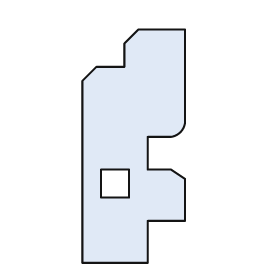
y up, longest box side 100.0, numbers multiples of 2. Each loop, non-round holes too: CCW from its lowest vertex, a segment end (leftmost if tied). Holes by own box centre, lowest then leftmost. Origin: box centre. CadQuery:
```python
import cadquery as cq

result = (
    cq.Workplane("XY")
    .moveTo(-22.0, -50.0)
    .lineTo(6.0, -50.0)
    .lineTo(6.0, -32.0)
    .lineTo(22.0, -32.0)
    .lineTo(22.0, -14.0)
    .lineTo(16.0, -10.0)
    .lineTo(6.0, -10.0)
    .lineTo(6.0, 4.0)
    .lineTo(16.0, 4.0)
    .threePointArc((20.0, 6.0), (22.0, 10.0))
    .lineTo(22.0, 50.0)
    .lineTo(2.0, 50.0)
    .lineTo(-4.0, 44.0)
    .lineTo(-4.0, 34.0)
    .lineTo(-16.0, 34.0)
    .lineTo(-22.0, 28.0)
    .close()
    .moveTo(-14.0, -22.0)
    .lineTo(-2.0, -22.0)
    .lineTo(-2.0, -10.0)
    .lineTo(-14.0, -10.0)
    .close()
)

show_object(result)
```